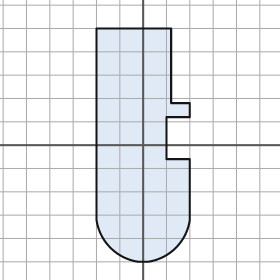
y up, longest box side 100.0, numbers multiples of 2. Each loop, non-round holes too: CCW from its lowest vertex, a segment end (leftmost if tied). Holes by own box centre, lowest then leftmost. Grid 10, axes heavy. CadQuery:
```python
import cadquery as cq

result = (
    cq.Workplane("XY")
    .moveTo(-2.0, -50.0)
    .lineTo(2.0, -50.0)
    .threePointArc((14.0, -44.0), (20.0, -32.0))
    .lineTo(20.0, -6.0)
    .lineTo(10.0, -6.0)
    .lineTo(10.0, 12.0)
    .lineTo(20.0, 12.0)
    .lineTo(20.0, 18.0)
    .lineTo(12.0, 18.0)
    .lineTo(12.0, 50.0)
    .lineTo(-20.0, 50.0)
    .lineTo(-20.0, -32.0)
    .threePointArc((-14.0, -44.0), (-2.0, -50.0))
    .close()
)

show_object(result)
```